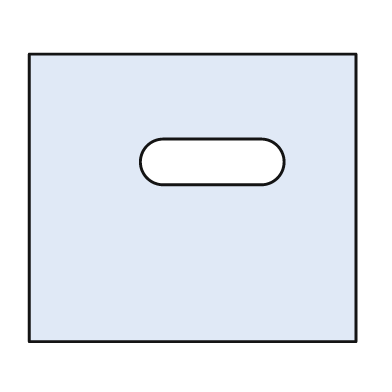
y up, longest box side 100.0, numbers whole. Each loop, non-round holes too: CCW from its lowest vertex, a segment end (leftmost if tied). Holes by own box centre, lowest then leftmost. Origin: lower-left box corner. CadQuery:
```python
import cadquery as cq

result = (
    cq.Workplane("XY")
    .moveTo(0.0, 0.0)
    .lineTo(100.0, 0.0)
    .lineTo(100.0, 88.0)
    .lineTo(0.0, 88.0)
    .close()
    .moveTo(41.0, 48.0)
    .lineTo(71.0, 48.0)
    .threePointArc((78.0, 55.0), (71.0, 62.0))
    .lineTo(41.0, 62.0)
    .threePointArc((34.0, 55.0), (41.0, 48.0))
    .close()
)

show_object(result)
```